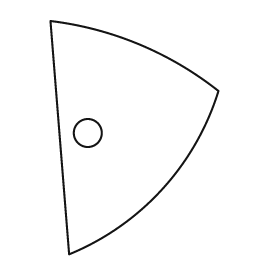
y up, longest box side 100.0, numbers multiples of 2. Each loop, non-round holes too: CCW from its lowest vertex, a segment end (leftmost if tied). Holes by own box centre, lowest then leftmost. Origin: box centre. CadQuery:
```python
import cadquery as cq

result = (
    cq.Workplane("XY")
    .moveTo(-28.0, -50.0)
    .threePointArc((12.0, -22.0), (36.0, 20.0))
    .threePointArc((2.0, 40.0), (-36.0, 50.0))
    .close()
    .moveTo(-20.0, 2.0)
    .circle(6.0)
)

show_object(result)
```